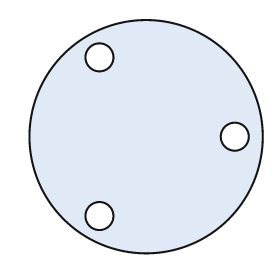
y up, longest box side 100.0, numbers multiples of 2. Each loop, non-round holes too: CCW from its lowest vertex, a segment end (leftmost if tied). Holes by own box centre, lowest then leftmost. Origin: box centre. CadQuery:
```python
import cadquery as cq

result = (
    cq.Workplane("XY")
    .moveTo(0.0, 0.0)
    .circle(50.0)
    .moveTo(-20.0, -34.0)
    .circle(6.0)
    .moveTo(38.0, 0.0)
    .circle(6.0)
    .moveTo(-20.0, 34.0)
    .circle(6.0)
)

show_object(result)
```